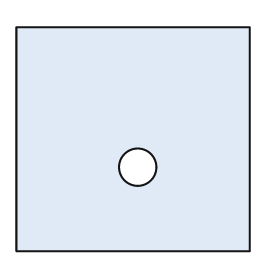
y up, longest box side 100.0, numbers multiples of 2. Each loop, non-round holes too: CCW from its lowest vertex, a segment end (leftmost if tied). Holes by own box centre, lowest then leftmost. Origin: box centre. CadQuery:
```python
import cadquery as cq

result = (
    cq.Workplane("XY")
    .moveTo(-50.0, -48.0)
    .lineTo(50.0, -48.0)
    .lineTo(50.0, 48.0)
    .lineTo(-50.0, 48.0)
    .close()
    .moveTo(2.0, -12.0)
    .circle(8.0)
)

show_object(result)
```